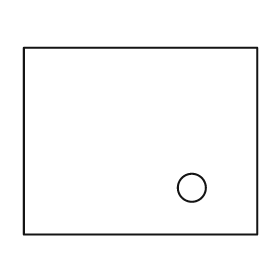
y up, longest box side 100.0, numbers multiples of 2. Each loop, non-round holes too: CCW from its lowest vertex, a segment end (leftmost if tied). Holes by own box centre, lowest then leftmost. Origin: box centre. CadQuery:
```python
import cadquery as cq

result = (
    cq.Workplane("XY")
    .moveTo(-50.0, -40.0)
    .lineTo(50.0, -40.0)
    .lineTo(50.0, 40.0)
    .lineTo(-50.0, 40.0)
    .close()
    .moveTo(22.0, -20.0)
    .circle(6.0)
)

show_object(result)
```